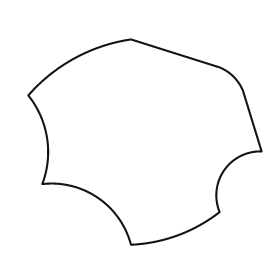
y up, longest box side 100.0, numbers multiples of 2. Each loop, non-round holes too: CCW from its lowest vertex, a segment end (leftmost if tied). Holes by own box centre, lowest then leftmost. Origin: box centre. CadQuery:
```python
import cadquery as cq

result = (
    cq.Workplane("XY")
    .moveTo(-6.0, -44.0)
    .threePointArc((14.0, -40.0), (32.0, -30.0))
    .threePointArc((34.0, -12.0), (50.0, -4.0))
    .lineTo(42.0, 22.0)
    .threePointArc((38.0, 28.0), (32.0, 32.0))
    .lineTo(-6.0, 44.0)
    .threePointArc((-30.0, 36.0), (-50.0, 20.0))
    .threePointArc((-42.0, 2.0), (-44.0, -18.0))
    .threePointArc((-20.0, -24.0), (-6.0, -44.0))
    .close()
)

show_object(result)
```